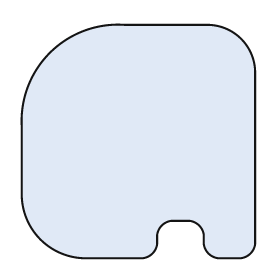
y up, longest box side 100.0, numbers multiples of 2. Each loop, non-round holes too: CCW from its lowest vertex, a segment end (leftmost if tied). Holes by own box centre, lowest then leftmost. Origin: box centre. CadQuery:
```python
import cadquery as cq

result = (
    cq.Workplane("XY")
    .moveTo(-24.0, -50.0)
    .lineTo(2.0, -50.0)
    .threePointArc((6.0, -48.0), (8.0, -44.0))
    .lineTo(8.0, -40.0)
    .threePointArc((10.0, -36.0), (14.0, -34.0))
    .lineTo(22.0, -34.0)
    .threePointArc((26.0, -36.0), (28.0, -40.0))
    .lineTo(28.0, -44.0)
    .threePointArc((30.0, -48.0), (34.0, -50.0))
    .lineTo(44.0, -50.0)
    .threePointArc((48.0, -48.0), (50.0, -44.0))
    .lineTo(50.0, 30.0)
    .threePointArc((44.0, 44.0), (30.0, 50.0))
    .lineTo(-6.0, 50.0)
    .threePointArc((-38.0, 38.0), (-50.0, 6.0))
    .lineTo(-50.0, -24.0)
    .threePointArc((-42.0, -42.0), (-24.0, -50.0))
    .close()
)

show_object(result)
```